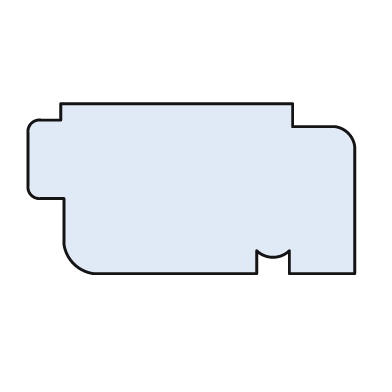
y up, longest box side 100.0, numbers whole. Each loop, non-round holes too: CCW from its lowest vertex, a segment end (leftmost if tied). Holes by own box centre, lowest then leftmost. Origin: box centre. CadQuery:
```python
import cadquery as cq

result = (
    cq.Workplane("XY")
    .moveTo(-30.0, -26.0)
    .lineTo(20.0, -26.0)
    .lineTo(20.0, -19.0)
    .threePointArc((25.0, -21.0), (30.0, -19.0))
    .lineTo(30.0, -26.0)
    .lineTo(50.0, -26.0)
    .lineTo(50.0, 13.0)
    .threePointArc((48.0, 17.0), (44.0, 19.0))
    .lineTo(31.0, 19.0)
    .lineTo(31.0, 26.0)
    .lineTo(-40.0, 26.0)
    .lineTo(-40.0, 21.0)
    .lineTo(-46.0, 21.0)
    .threePointArc((-49.0, 20.0), (-50.0, 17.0))
    .lineTo(-50.0, 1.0)
    .threePointArc((-49.0, -2.0), (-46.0, -3.0))
    .lineTo(-39.0, -3.0)
    .lineTo(-39.0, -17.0)
    .threePointArc((-36.0, -23.0), (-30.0, -26.0))
    .close()
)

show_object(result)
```